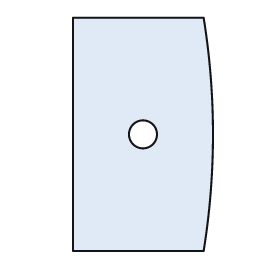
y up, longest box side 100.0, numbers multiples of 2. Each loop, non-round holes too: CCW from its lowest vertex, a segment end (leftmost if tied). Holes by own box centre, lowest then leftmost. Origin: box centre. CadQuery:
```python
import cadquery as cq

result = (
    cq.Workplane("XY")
    .moveTo(-30.0, -50.0)
    .lineTo(26.0, -50.0)
    .threePointArc((30.0, 0.0), (26.0, 50.0))
    .lineTo(-30.0, 50.0)
    .close()
    .moveTo(0.0, 0.0)
    .circle(6.0)
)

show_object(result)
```